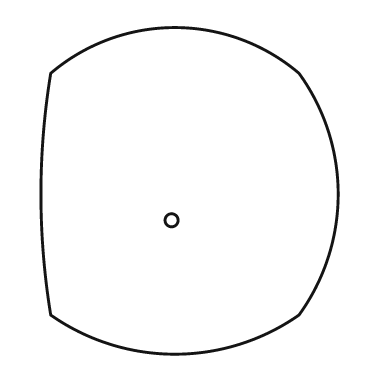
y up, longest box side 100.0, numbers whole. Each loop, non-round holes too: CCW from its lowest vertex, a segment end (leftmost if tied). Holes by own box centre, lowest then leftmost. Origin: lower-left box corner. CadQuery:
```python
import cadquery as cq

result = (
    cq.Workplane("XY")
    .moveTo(3.0, 12.0)
    .threePointArc((41.0, 0.0), (79.0, 12.0))
    .threePointArc((91.0, 49.0), (79.0, 86.0))
    .threePointArc((41.0, 100.0), (3.0, 86.0))
    .threePointArc((0.0, 49.0), (3.0, 12.0))
    .close()
    .moveTo(40.0, 41.0)
    .circle(2.0)
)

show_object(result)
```